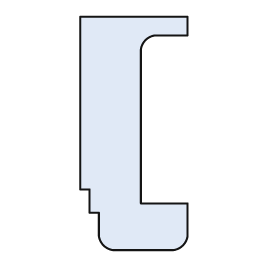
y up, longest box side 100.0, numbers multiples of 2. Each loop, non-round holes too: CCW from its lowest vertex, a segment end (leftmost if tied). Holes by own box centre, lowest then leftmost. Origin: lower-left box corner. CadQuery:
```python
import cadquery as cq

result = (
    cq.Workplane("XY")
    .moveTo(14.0, 0.0)
    .lineTo(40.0, 0.0)
    .threePointArc((44.0, 2.0), (46.0, 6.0))
    .lineTo(46.0, 20.0)
    .lineTo(26.0, 20.0)
    .lineTo(26.0, 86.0)
    .threePointArc((28.0, 90.0), (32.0, 92.0))
    .lineTo(46.0, 92.0)
    .lineTo(46.0, 100.0)
    .lineTo(0.0, 100.0)
    .lineTo(0.0, 26.0)
    .lineTo(4.0, 26.0)
    .lineTo(4.0, 16.0)
    .lineTo(8.0, 16.0)
    .lineTo(8.0, 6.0)
    .threePointArc((10.0, 2.0), (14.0, 0.0))
    .close()
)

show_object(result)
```